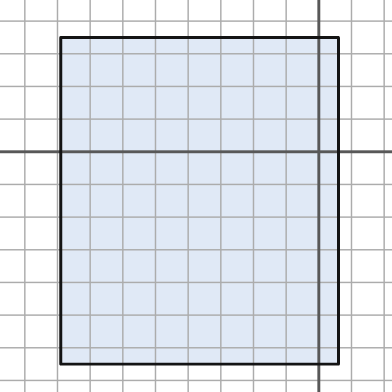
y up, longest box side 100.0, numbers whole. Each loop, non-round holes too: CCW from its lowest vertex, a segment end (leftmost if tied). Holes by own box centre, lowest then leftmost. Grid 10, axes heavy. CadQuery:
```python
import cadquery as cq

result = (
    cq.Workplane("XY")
    .moveTo(-79.0, -65.0)
    .lineTo(6.0, -65.0)
    .lineTo(6.0, 35.0)
    .lineTo(-79.0, 35.0)
    .close()
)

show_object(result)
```